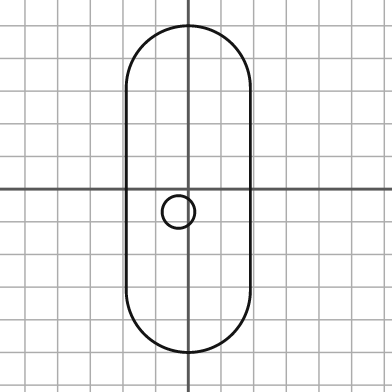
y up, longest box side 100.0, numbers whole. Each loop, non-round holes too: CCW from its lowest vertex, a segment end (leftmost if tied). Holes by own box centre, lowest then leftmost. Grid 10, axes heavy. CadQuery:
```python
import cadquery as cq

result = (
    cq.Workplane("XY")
    .moveTo(-19.0, -31.0)
    .threePointArc((0.0, -50.0), (19.0, -31.0))
    .lineTo(19.0, 31.0)
    .threePointArc((0.0, 50.0), (-19.0, 31.0))
    .close()
    .moveTo(-3.0, -7.0)
    .circle(5.0)
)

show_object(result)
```